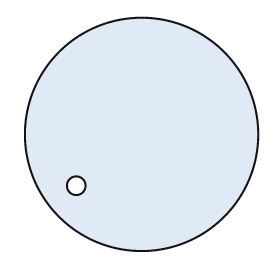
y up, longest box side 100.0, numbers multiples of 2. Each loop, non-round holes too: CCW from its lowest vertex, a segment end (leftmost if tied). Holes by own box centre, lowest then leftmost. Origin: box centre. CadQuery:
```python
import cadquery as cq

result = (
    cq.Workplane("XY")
    .moveTo(0.0, 0.0)
    .circle(50.0)
    .moveTo(-28.0, -22.0)
    .circle(4.0)
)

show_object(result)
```